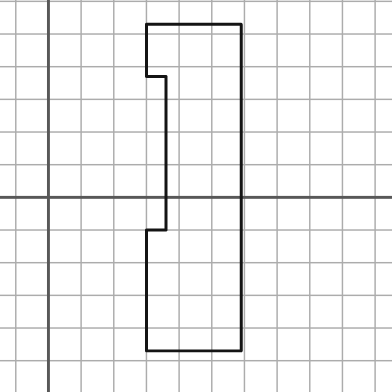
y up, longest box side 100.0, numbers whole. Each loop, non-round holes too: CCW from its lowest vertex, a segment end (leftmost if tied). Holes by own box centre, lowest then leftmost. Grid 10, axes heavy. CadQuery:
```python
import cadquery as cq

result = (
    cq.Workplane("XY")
    .moveTo(30.0, -47.0)
    .lineTo(59.0, -47.0)
    .lineTo(59.0, 53.0)
    .lineTo(30.0, 53.0)
    .lineTo(30.0, 37.0)
    .lineTo(36.0, 37.0)
    .lineTo(36.0, -10.0)
    .lineTo(30.0, -10.0)
    .close()
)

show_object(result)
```